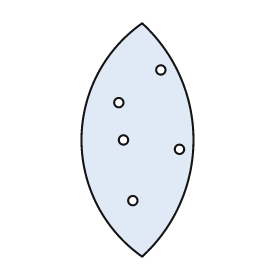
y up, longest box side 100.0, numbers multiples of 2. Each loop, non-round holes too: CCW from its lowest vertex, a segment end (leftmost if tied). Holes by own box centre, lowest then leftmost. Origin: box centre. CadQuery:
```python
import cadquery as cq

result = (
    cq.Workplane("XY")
    .moveTo(2.0, -50.0)
    .threePointArc((24.0, 0.0), (2.0, 50.0))
    .threePointArc((-24.0, 0.0), (2.0, -50.0))
    .close()
    .moveTo(-2.0, -26.0)
    .circle(2.0)
    .moveTo(18.0, -4.0)
    .circle(2.0)
    .moveTo(-6.0, 0.0)
    .circle(2.0)
    .moveTo(-8.0, 16.0)
    .circle(2.0)
    .moveTo(10.0, 30.0)
    .circle(2.0)
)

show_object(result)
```